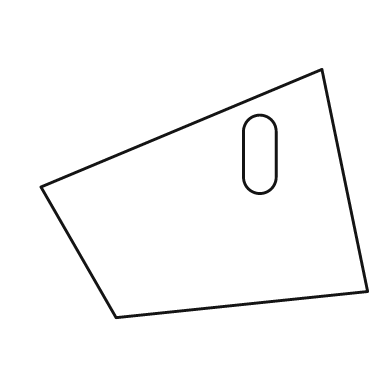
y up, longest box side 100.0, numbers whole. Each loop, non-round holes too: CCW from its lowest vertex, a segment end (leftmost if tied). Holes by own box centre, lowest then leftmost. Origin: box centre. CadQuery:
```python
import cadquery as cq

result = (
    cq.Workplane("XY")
    .moveTo(-27.0, -38.0)
    .lineTo(50.0, -30.0)
    .lineTo(36.0, 38.0)
    .lineTo(-50.0, 2.0)
    .close()
    .moveTo(12.0, 5.0)
    .threePointArc((17.0, 0.0), (22.0, 5.0))
    .lineTo(22.0, 19.0)
    .threePointArc((17.0, 24.0), (12.0, 19.0))
    .close()
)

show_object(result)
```